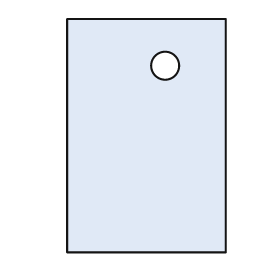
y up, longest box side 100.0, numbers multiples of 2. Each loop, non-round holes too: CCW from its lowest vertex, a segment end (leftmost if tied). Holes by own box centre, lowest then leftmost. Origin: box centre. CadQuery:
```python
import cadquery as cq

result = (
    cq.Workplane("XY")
    .moveTo(-34.0, -50.0)
    .lineTo(34.0, -50.0)
    .lineTo(34.0, 50.0)
    .lineTo(-34.0, 50.0)
    .close()
    .moveTo(8.0, 30.0)
    .circle(6.0)
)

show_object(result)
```